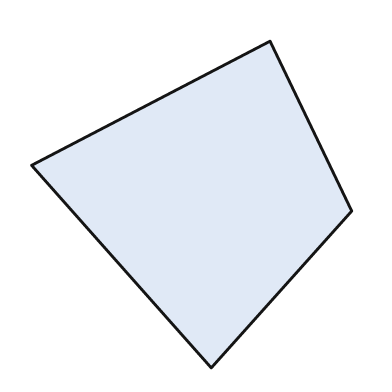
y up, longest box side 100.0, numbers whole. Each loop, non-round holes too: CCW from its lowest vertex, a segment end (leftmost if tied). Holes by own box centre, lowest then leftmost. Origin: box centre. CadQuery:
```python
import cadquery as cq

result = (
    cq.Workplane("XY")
    .moveTo(6.0, -50.0)
    .lineTo(49.0, -2.0)
    .lineTo(24.0, 50.0)
    .lineTo(-49.0, 12.0)
    .close()
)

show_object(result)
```